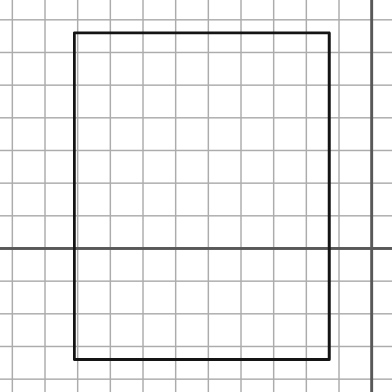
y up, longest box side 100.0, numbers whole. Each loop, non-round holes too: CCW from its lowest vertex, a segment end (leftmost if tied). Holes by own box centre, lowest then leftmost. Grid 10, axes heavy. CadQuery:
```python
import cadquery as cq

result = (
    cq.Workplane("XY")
    .moveTo(-91.0, -34.0)
    .lineTo(-13.0, -34.0)
    .lineTo(-13.0, 66.0)
    .lineTo(-91.0, 66.0)
    .close()
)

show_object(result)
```